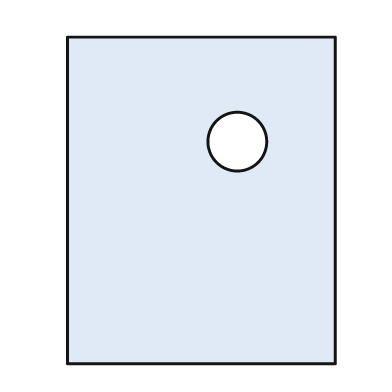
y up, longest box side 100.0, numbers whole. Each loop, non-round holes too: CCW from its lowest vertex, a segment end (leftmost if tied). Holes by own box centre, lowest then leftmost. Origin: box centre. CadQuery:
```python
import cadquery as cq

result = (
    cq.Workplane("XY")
    .moveTo(-41.0, -50.0)
    .lineTo(41.0, -50.0)
    .lineTo(41.0, 50.0)
    .lineTo(-41.0, 50.0)
    .close()
    .moveTo(11.0, 18.0)
    .circle(9.0)
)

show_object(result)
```